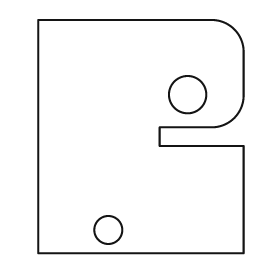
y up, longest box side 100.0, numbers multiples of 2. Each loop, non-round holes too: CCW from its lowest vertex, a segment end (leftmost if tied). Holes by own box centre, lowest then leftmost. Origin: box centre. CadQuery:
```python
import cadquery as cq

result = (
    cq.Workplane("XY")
    .moveTo(-44.0, -50.0)
    .lineTo(44.0, -50.0)
    .lineTo(44.0, -4.0)
    .lineTo(8.0, -4.0)
    .lineTo(8.0, 4.0)
    .lineTo(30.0, 4.0)
    .threePointArc((40.0, 8.0), (44.0, 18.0))
    .lineTo(44.0, 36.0)
    .threePointArc((40.0, 46.0), (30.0, 50.0))
    .lineTo(-44.0, 50.0)
    .close()
    .moveTo(-14.0, -40.0)
    .circle(6.0)
    .moveTo(20.0, 18.0)
    .circle(8.0)
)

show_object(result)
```